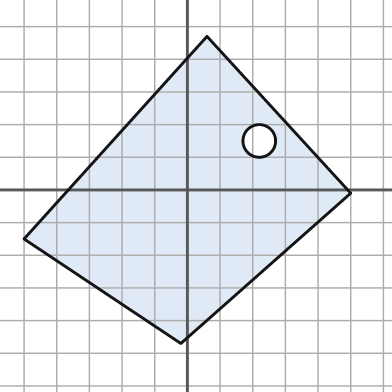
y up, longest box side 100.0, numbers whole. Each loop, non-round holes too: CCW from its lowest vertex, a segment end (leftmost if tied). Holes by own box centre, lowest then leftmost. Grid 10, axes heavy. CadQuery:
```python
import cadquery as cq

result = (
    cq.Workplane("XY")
    .moveTo(-2.0, -47.0)
    .lineTo(50.0, -1.0)
    .lineTo(6.0, 47.0)
    .lineTo(-50.0, -15.0)
    .close()
    .moveTo(22.0, 15.0)
    .circle(5.0)
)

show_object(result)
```